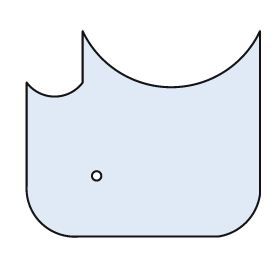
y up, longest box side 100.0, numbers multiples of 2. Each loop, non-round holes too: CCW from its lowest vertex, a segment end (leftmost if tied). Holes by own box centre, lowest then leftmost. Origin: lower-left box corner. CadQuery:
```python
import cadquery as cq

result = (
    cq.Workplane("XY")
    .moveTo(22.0, 0.0)
    .lineTo(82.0, 0.0)
    .threePointArc((94.0, 6.0), (100.0, 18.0))
    .lineTo(100.0, 88.0)
    .threePointArc((62.0, 64.0), (24.0, 88.0))
    .lineTo(24.0, 66.0)
    .threePointArc((12.0, 60.0), (0.0, 66.0))
    .lineTo(0.0, 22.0)
    .threePointArc((6.0, 6.0), (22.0, 0.0))
    .close()
    .moveTo(30.0, 26.0)
    .circle(2.0)
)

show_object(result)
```